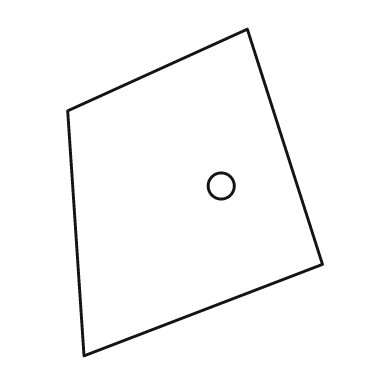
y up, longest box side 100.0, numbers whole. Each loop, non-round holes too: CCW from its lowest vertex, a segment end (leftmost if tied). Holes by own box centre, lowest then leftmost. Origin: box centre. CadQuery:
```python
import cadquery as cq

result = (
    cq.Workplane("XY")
    .moveTo(-34.0, -50.0)
    .lineTo(39.0, -22.0)
    .lineTo(16.0, 50.0)
    .lineTo(-39.0, 25.0)
    .close()
    .moveTo(8.0, 2.0)
    .circle(4.0)
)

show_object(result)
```